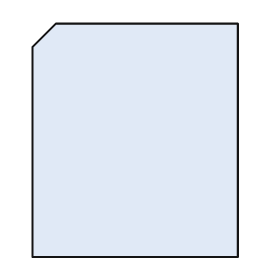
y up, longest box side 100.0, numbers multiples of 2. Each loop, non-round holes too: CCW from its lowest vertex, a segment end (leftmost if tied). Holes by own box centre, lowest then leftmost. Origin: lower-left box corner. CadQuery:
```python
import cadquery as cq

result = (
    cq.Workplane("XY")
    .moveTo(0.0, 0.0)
    .lineTo(88.0, 0.0)
    .lineTo(88.0, 100.0)
    .lineTo(10.0, 100.0)
    .lineTo(0.0, 90.0)
    .close()
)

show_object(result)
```